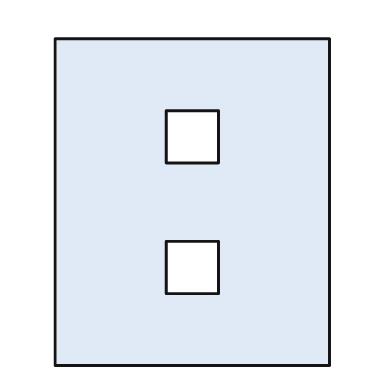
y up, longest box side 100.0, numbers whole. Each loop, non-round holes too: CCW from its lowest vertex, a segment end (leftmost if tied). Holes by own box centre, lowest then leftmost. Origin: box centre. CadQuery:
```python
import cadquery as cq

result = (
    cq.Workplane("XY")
    .moveTo(-42.0, -50.0)
    .lineTo(42.0, -50.0)
    .lineTo(42.0, 50.0)
    .lineTo(-42.0, 50.0)
    .close()
    .moveTo(-8.0, -28.0)
    .lineTo(8.0, -28.0)
    .lineTo(8.0, -12.0)
    .lineTo(-8.0, -12.0)
    .close()
    .moveTo(-8.0, 12.0)
    .lineTo(8.0, 12.0)
    .lineTo(8.0, 28.0)
    .lineTo(-8.0, 28.0)
    .close()
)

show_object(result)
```